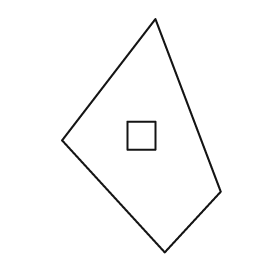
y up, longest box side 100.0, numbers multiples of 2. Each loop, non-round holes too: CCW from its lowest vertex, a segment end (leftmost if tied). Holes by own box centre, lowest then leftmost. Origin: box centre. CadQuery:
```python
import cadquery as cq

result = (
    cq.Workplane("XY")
    .moveTo(10.0, -50.0)
    .lineTo(34.0, -24.0)
    .lineTo(6.0, 50.0)
    .lineTo(-34.0, -2.0)
    .close()
    .moveTo(-6.0, -6.0)
    .lineTo(6.0, -6.0)
    .lineTo(6.0, 6.0)
    .lineTo(-6.0, 6.0)
    .close()
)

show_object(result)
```